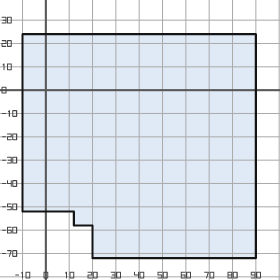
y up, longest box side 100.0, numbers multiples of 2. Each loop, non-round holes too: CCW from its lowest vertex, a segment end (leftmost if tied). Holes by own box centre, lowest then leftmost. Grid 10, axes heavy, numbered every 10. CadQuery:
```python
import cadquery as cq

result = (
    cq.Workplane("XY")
    .moveTo(20.0, -72.0)
    .lineTo(90.0, -72.0)
    .lineTo(90.0, 24.0)
    .lineTo(-10.0, 24.0)
    .lineTo(-10.0, -52.0)
    .lineTo(12.0, -52.0)
    .lineTo(12.0, -58.0)
    .lineTo(20.0, -58.0)
    .close()
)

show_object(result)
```